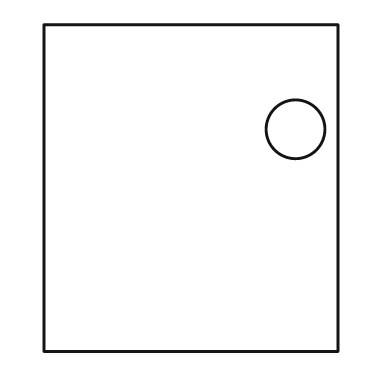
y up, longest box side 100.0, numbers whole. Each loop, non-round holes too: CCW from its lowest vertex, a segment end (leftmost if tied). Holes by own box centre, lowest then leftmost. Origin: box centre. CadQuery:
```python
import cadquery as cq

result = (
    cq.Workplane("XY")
    .moveTo(-45.0, -50.0)
    .lineTo(45.0, -50.0)
    .lineTo(45.0, 50.0)
    .lineTo(-45.0, 50.0)
    .close()
    .moveTo(32.0, 18.0)
    .circle(9.0)
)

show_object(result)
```